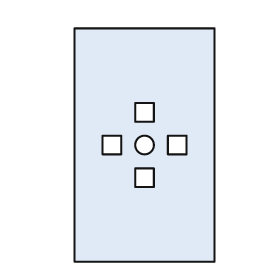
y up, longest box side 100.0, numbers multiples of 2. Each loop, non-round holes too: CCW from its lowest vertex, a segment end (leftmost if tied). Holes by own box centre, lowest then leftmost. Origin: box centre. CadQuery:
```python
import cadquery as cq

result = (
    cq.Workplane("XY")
    .moveTo(-30.0, -50.0)
    .lineTo(30.0, -50.0)
    .lineTo(30.0, 50.0)
    .lineTo(-30.0, 50.0)
    .close()
    .moveTo(-4.0, -18.0)
    .lineTo(4.0, -18.0)
    .lineTo(4.0, -10.0)
    .lineTo(-4.0, -10.0)
    .close()
    .moveTo(-18.0, -4.0)
    .lineTo(-10.0, -4.0)
    .lineTo(-10.0, 4.0)
    .lineTo(-18.0, 4.0)
    .close()
    .moveTo(0.0, 0.0)
    .circle(4.0)
    .moveTo(10.0, -4.0)
    .lineTo(18.0, -4.0)
    .lineTo(18.0, 4.0)
    .lineTo(10.0, 4.0)
    .close()
    .moveTo(-4.0, 10.0)
    .lineTo(4.0, 10.0)
    .lineTo(4.0, 18.0)
    .lineTo(-4.0, 18.0)
    .close()
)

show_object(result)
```